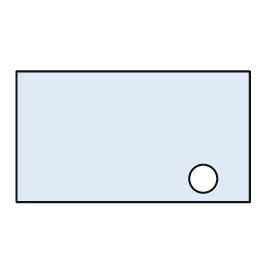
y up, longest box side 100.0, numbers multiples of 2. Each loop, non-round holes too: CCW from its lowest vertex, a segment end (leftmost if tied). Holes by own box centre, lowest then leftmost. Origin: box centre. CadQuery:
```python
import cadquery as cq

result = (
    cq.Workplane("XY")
    .moveTo(-50.0, -28.0)
    .lineTo(50.0, -28.0)
    .lineTo(50.0, 28.0)
    .lineTo(-50.0, 28.0)
    .close()
    .moveTo(30.0, -18.0)
    .circle(6.0)
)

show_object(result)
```